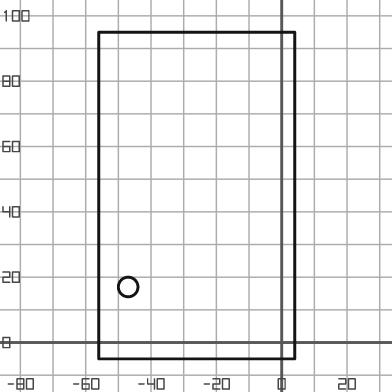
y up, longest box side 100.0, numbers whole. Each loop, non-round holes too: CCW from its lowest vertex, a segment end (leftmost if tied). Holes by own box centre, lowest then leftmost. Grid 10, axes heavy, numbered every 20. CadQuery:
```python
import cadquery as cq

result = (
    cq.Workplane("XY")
    .moveTo(-56.0, -5.0)
    .lineTo(4.0, -5.0)
    .lineTo(4.0, 95.0)
    .lineTo(-56.0, 95.0)
    .close()
    .moveTo(-47.0, 17.0)
    .circle(3.0)
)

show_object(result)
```